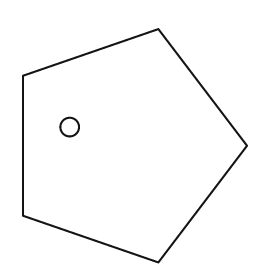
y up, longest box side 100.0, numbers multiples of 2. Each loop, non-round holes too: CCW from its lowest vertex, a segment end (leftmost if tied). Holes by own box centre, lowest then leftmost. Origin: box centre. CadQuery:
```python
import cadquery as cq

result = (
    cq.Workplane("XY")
    .moveTo(10.0, -50.0)
    .lineTo(48.0, 0.0)
    .lineTo(10.0, 50.0)
    .lineTo(-48.0, 30.0)
    .lineTo(-48.0, -30.0)
    .close()
    .moveTo(-28.0, 8.0)
    .circle(4.0)
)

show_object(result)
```